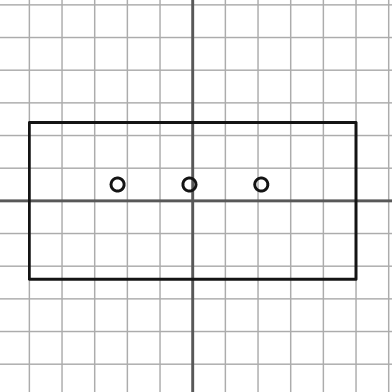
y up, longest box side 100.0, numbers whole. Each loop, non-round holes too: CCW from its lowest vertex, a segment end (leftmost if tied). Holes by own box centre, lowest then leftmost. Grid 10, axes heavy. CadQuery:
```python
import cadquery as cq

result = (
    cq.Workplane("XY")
    .moveTo(-50.0, -24.0)
    .lineTo(50.0, -24.0)
    .lineTo(50.0, 24.0)
    .lineTo(-50.0, 24.0)
    .close()
    .moveTo(-23.0, 5.0)
    .circle(2.0)
    .moveTo(-1.0, 5.0)
    .circle(2.0)
    .moveTo(21.0, 5.0)
    .circle(2.0)
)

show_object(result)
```